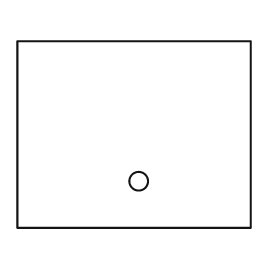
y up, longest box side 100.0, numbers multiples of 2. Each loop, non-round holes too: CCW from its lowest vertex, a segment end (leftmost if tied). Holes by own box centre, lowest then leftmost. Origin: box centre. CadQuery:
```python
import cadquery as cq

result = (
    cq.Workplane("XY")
    .moveTo(-50.0, -40.0)
    .lineTo(50.0, -40.0)
    .lineTo(50.0, 40.0)
    .lineTo(-50.0, 40.0)
    .close()
    .moveTo(2.0, -20.0)
    .circle(4.0)
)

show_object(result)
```